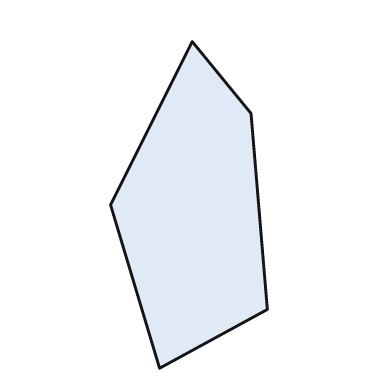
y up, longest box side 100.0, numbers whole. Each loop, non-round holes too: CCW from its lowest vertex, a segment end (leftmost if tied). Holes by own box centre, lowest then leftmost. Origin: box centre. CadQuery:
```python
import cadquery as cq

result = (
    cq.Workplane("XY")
    .moveTo(-9.0, -50.0)
    .lineTo(24.0, -32.0)
    .lineTo(19.0, 28.0)
    .lineTo(1.0, 50.0)
    .lineTo(-24.0, 0.0)
    .close()
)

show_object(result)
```